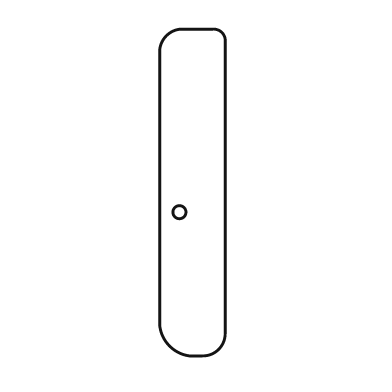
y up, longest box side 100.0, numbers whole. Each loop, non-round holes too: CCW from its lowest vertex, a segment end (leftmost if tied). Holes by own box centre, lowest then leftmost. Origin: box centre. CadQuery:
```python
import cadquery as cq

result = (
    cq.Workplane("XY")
    .moveTo(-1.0, -50.0)
    .lineTo(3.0, -50.0)
    .threePointArc((8.0, -48.0), (10.0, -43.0))
    .lineTo(10.0, 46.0)
    .threePointArc((9.0, 49.0), (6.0, 50.0))
    .lineTo(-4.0, 50.0)
    .threePointArc((-8.0, 48.0), (-10.0, 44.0))
    .lineTo(-10.0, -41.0)
    .threePointArc((-7.0, -47.0), (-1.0, -50.0))
    .close()
    .moveTo(-4.0, -6.0)
    .circle(2.0)
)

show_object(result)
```